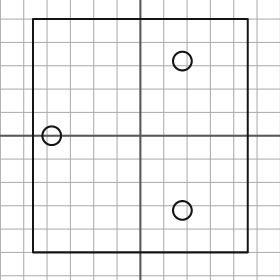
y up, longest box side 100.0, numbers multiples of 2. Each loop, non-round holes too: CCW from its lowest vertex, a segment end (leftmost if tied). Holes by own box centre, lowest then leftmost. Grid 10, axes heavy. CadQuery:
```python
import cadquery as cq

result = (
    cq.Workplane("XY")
    .moveTo(-46.0, -50.0)
    .lineTo(46.0, -50.0)
    .lineTo(46.0, 50.0)
    .lineTo(-46.0, 50.0)
    .close()
    .moveTo(18.0, -32.0)
    .circle(4.0)
    .moveTo(-38.0, 0.0)
    .circle(4.0)
    .moveTo(18.0, 32.0)
    .circle(4.0)
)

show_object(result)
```